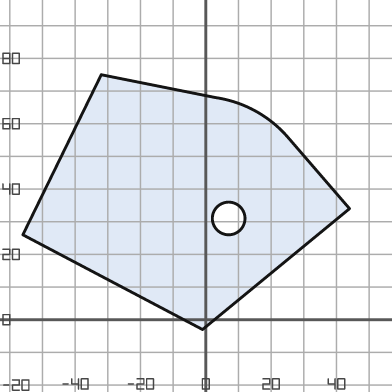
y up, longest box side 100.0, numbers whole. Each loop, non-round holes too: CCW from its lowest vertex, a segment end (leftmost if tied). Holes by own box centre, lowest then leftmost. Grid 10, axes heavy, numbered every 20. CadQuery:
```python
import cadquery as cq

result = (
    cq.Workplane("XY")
    .moveTo(-1.0, -3.0)
    .lineTo(44.0, 34.0)
    .lineTo(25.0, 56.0)
    .threePointArc((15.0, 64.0), (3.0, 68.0))
    .lineTo(-32.0, 75.0)
    .lineTo(-56.0, 26.0)
    .close()
    .moveTo(7.0, 31.0)
    .circle(5.0)
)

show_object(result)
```